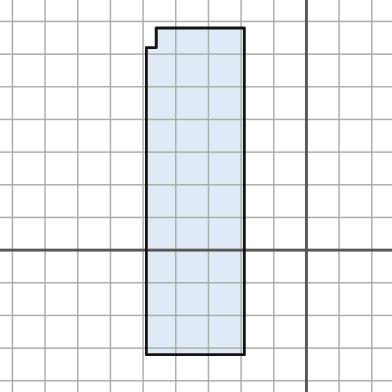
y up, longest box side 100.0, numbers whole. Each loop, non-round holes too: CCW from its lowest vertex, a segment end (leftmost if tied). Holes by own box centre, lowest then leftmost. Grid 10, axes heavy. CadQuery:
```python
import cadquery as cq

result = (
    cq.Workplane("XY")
    .moveTo(-49.0, -32.0)
    .lineTo(-19.0, -32.0)
    .lineTo(-19.0, 68.0)
    .lineTo(-46.0, 68.0)
    .lineTo(-46.0, 62.0)
    .lineTo(-49.0, 62.0)
    .close()
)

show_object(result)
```